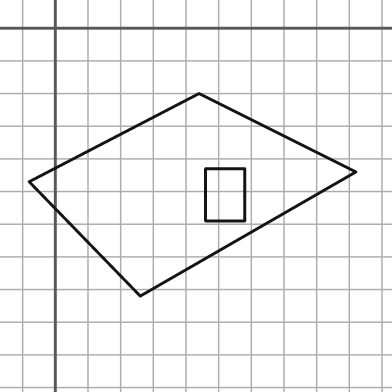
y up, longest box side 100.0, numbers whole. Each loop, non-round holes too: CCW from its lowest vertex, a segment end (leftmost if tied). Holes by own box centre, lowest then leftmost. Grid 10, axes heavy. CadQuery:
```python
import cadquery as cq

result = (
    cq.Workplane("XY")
    .moveTo(26.0, -82.0)
    .lineTo(92.0, -44.0)
    .lineTo(44.0, -20.0)
    .lineTo(-8.0, -47.0)
    .close()
    .moveTo(46.0, -59.0)
    .lineTo(58.0, -59.0)
    .lineTo(58.0, -43.0)
    .lineTo(46.0, -43.0)
    .close()
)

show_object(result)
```